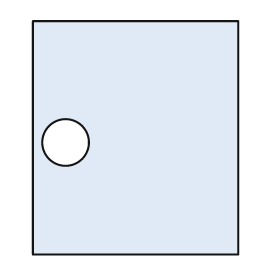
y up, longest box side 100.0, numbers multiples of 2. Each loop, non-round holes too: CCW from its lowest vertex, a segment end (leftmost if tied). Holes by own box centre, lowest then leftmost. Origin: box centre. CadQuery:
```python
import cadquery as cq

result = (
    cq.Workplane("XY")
    .moveTo(-44.0, -50.0)
    .lineTo(44.0, -50.0)
    .lineTo(44.0, 50.0)
    .lineTo(-44.0, 50.0)
    .close()
    .moveTo(-30.0, -2.0)
    .circle(10.0)
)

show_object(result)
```